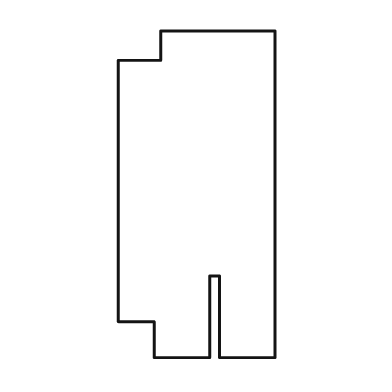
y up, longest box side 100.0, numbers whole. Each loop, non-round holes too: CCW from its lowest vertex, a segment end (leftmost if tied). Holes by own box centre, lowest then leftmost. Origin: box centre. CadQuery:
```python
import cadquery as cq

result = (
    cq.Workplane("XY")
    .moveTo(-13.0, -50.0)
    .lineTo(4.0, -50.0)
    .lineTo(4.0, -25.0)
    .lineTo(7.0, -25.0)
    .lineTo(7.0, -50.0)
    .lineTo(24.0, -50.0)
    .lineTo(24.0, 50.0)
    .lineTo(-11.0, 50.0)
    .lineTo(-11.0, 41.0)
    .lineTo(-24.0, 41.0)
    .lineTo(-24.0, -39.0)
    .lineTo(-13.0, -39.0)
    .close()
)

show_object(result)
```